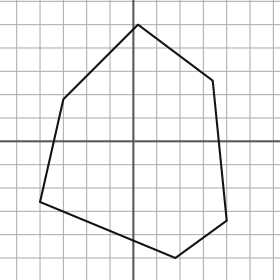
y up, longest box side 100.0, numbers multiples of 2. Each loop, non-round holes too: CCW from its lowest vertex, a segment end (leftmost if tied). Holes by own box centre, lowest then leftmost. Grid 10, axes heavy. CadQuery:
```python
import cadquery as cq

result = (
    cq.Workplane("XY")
    .moveTo(18.0, -50.0)
    .lineTo(40.0, -34.0)
    .lineTo(34.0, 26.0)
    .lineTo(2.0, 50.0)
    .lineTo(-30.0, 18.0)
    .lineTo(-40.0, -26.0)
    .close()
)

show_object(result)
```